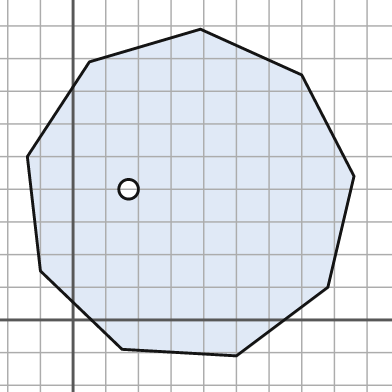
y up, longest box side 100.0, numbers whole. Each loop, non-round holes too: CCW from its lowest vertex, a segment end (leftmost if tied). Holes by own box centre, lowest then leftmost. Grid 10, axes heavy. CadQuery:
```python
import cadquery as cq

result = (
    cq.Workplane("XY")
    .moveTo(50.0, -11.0)
    .lineTo(78.0, 10.0)
    .lineTo(86.0, 44.0)
    .lineTo(70.0, 75.0)
    .lineTo(39.0, 89.0)
    .lineTo(5.0, 79.0)
    .lineTo(-14.0, 50.0)
    .lineTo(-10.0, 15.0)
    .lineTo(15.0, -9.0)
    .close()
    .moveTo(17.0, 40.0)
    .circle(3.0)
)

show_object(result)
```